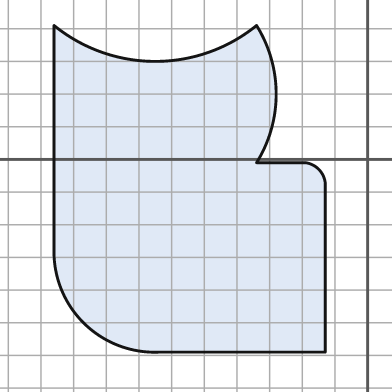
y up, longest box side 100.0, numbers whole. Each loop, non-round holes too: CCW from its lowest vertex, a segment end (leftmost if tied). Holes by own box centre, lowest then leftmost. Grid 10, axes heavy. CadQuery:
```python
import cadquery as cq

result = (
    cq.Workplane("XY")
    .moveTo(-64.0, -59.0)
    .lineTo(-13.0, -59.0)
    .lineTo(-13.0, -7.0)
    .threePointArc((-15.0, -3.0), (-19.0, -1.0))
    .lineTo(-34.0, -1.0)
    .threePointArc((-28.0, 20.0), (-34.0, 41.0))
    .threePointArc((-65.0, 30.0), (-96.0, 41.0))
    .lineTo(-96.0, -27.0)
    .threePointArc((-87.0, -50.0), (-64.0, -59.0))
    .close()
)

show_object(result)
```